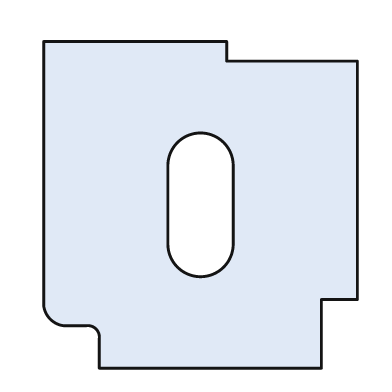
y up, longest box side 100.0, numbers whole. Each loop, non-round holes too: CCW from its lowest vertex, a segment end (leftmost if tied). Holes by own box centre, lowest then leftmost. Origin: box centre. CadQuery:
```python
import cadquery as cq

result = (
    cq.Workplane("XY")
    .moveTo(-31.0, -50.0)
    .lineTo(37.0, -50.0)
    .lineTo(37.0, -29.0)
    .lineTo(48.0, -29.0)
    .lineTo(48.0, 44.0)
    .lineTo(8.0, 44.0)
    .lineTo(8.0, 50.0)
    .lineTo(-48.0, 50.0)
    .lineTo(-48.0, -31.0)
    .threePointArc((-46.0, -35.0), (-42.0, -37.0))
    .lineTo(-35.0, -37.0)
    .threePointArc((-32.0, -38.0), (-31.0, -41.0))
    .close()
    .moveTo(-10.0, -12.0)
    .threePointArc((0.0, -22.0), (10.0, -12.0))
    .lineTo(10.0, 12.0)
    .threePointArc((0.0, 22.0), (-10.0, 12.0))
    .close()
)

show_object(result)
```